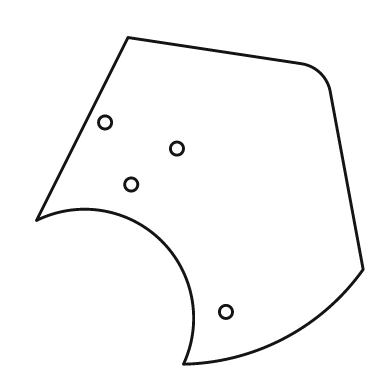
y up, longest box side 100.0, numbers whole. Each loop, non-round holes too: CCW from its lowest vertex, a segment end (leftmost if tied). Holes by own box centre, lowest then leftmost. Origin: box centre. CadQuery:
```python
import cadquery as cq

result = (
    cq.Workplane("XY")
    .moveTo(-5.0, -50.0)
    .threePointArc((26.0, -42.0), (50.0, -21.0))
    .lineTo(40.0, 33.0)
    .threePointArc((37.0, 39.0), (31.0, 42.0))
    .lineTo(-22.0, 50.0)
    .lineTo(-50.0, -6.0)
    .threePointArc((-12.0, -12.0), (-5.0, -50.0))
    .close()
    .moveTo(8.0, -34.0)
    .circle(2.0)
    .moveTo(-21.0, 5.0)
    .circle(2.0)
    .moveTo(-7.0, 16.0)
    .circle(2.0)
    .moveTo(-29.0, 24.0)
    .circle(2.0)
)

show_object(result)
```